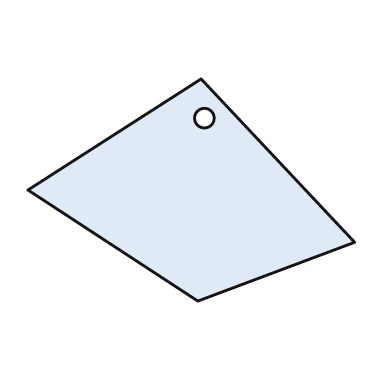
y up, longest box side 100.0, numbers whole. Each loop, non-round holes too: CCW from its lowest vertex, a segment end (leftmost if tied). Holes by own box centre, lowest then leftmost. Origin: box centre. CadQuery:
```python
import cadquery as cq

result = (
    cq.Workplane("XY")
    .moveTo(2.0, -34.0)
    .lineTo(50.0, -16.0)
    .lineTo(3.0, 34.0)
    .lineTo(-50.0, 0.0)
    .close()
    .moveTo(4.0, 22.0)
    .circle(3.0)
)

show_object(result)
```